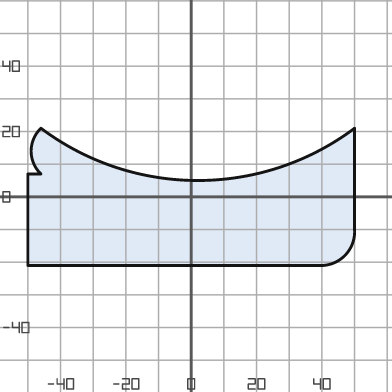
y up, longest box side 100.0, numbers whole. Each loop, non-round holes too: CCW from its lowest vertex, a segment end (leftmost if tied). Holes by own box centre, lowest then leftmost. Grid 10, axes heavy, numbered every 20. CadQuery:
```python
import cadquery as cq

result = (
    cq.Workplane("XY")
    .moveTo(-50.0, -21.0)
    .lineTo(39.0, -21.0)
    .threePointArc((47.0, -18.0), (50.0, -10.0))
    .lineTo(50.0, 21.0)
    .threePointArc((2.0, 5.0), (-46.0, 21.0))
    .threePointArc((-49.0, 14.0), (-46.0, 7.0))
    .lineTo(-50.0, 7.0)
    .close()
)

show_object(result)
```